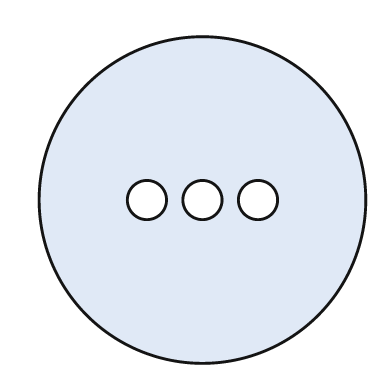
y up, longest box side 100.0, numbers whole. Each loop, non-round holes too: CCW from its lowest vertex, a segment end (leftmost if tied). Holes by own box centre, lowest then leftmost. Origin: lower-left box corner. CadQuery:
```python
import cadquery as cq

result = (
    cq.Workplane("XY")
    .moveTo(50.0, 50.0)
    .circle(50.0)
    .moveTo(33.0, 50.0)
    .circle(6.0)
    .moveTo(50.0, 50.0)
    .circle(6.0)
    .moveTo(67.0, 50.0)
    .circle(6.0)
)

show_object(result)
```